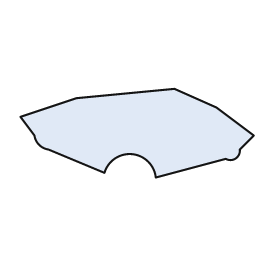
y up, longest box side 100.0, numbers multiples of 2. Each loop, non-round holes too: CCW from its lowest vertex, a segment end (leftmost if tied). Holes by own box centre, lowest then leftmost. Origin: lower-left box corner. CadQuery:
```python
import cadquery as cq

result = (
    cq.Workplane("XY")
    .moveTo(58.0, 0.0)
    .lineTo(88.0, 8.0)
    .threePointArc((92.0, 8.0), (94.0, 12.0))
    .lineTo(100.0, 18.0)
    .lineTo(84.0, 30.0)
    .lineTo(66.0, 38.0)
    .lineTo(24.0, 34.0)
    .lineTo(0.0, 26.0)
    .lineTo(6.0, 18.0)
    .threePointArc((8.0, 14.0), (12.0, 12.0))
    .lineTo(36.0, 2.0)
    .threePointArc((48.0, 10.0), (58.0, 0.0))
    .close()
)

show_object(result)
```